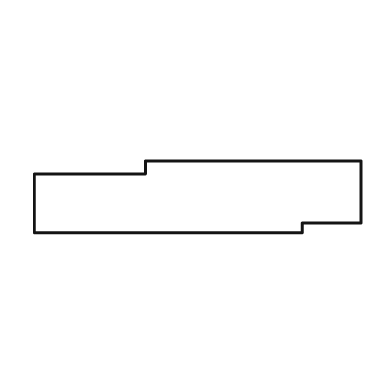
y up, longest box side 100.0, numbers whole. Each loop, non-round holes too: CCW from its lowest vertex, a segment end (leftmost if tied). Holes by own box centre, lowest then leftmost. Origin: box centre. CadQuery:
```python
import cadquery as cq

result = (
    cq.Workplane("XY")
    .moveTo(-50.0, -11.0)
    .lineTo(32.0, -11.0)
    .lineTo(32.0, -8.0)
    .lineTo(50.0, -8.0)
    .lineTo(50.0, 11.0)
    .lineTo(-16.0, 11.0)
    .lineTo(-16.0, 7.0)
    .lineTo(-50.0, 7.0)
    .close()
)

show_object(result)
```